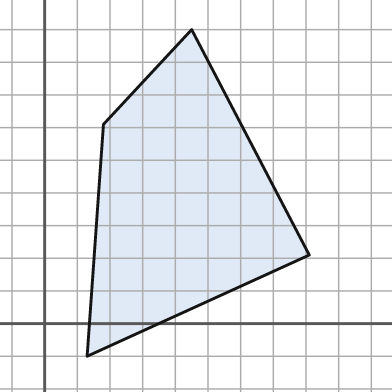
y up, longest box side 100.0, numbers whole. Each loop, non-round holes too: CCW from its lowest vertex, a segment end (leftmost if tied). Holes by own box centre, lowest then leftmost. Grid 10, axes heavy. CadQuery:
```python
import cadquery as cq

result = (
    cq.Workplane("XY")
    .moveTo(13.0, -10.0)
    .lineTo(81.0, 21.0)
    .lineTo(45.0, 90.0)
    .lineTo(18.0, 61.0)
    .close()
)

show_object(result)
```